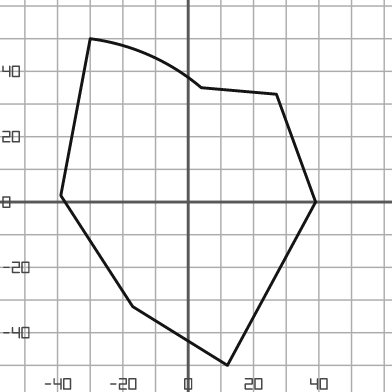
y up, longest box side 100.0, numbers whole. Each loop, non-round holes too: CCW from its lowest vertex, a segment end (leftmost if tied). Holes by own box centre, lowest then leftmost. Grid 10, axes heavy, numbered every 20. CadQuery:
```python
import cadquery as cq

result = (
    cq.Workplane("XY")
    .moveTo(12.0, -50.0)
    .lineTo(39.0, 0.0)
    .lineTo(27.0, 33.0)
    .lineTo(4.0, 35.0)
    .threePointArc((-12.0, 45.0), (-30.0, 50.0))
    .lineTo(-39.0, 2.0)
    .lineTo(-17.0, -32.0)
    .close()
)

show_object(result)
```